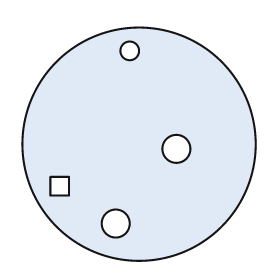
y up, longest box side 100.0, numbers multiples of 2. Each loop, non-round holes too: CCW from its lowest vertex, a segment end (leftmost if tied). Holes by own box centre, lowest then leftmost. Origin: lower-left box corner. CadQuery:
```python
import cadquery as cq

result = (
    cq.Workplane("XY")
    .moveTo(50.0, 50.0)
    .circle(50.0)
    .moveTo(40.0, 16.0)
    .circle(6.0)
    .moveTo(12.0, 28.0)
    .lineTo(20.0, 28.0)
    .lineTo(20.0, 36.0)
    .lineTo(12.0, 36.0)
    .close()
    .moveTo(66.0, 48.0)
    .circle(6.0)
    .moveTo(46.0, 90.0)
    .circle(4.0)
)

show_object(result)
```